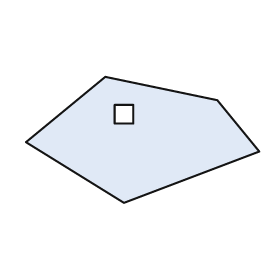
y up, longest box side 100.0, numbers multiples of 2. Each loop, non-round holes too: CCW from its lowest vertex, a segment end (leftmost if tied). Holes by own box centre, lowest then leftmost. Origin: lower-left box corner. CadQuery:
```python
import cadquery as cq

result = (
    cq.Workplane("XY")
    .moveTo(42.0, 0.0)
    .lineTo(100.0, 22.0)
    .lineTo(82.0, 44.0)
    .lineTo(34.0, 54.0)
    .lineTo(0.0, 26.0)
    .close()
    .moveTo(38.0, 34.0)
    .lineTo(46.0, 34.0)
    .lineTo(46.0, 42.0)
    .lineTo(38.0, 42.0)
    .close()
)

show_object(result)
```